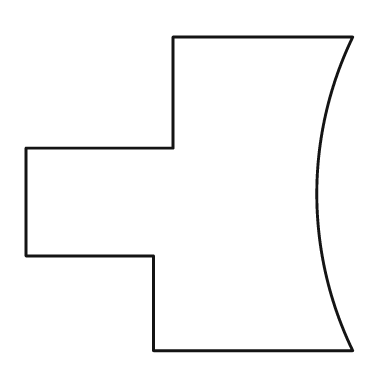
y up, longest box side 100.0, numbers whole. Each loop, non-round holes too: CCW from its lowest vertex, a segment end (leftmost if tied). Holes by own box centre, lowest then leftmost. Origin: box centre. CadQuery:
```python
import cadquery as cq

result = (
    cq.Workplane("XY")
    .moveTo(-11.0, -48.0)
    .lineTo(50.0, -48.0)
    .threePointArc((39.0, 0.0), (50.0, 48.0))
    .lineTo(-5.0, 48.0)
    .lineTo(-5.0, 14.0)
    .lineTo(-50.0, 14.0)
    .lineTo(-50.0, -19.0)
    .lineTo(-11.0, -19.0)
    .close()
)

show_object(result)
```